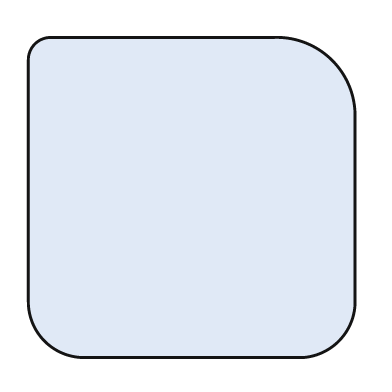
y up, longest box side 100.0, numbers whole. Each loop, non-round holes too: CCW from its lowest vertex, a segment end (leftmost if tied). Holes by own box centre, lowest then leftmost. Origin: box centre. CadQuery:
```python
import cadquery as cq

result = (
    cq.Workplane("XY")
    .moveTo(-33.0, -49.0)
    .lineTo(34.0, -49.0)
    .threePointArc((45.0, -44.0), (50.0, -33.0))
    .lineTo(50.0, 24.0)
    .threePointArc((43.0, 42.0), (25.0, 49.0))
    .lineTo(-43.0, 49.0)
    .threePointArc((-48.0, 47.0), (-50.0, 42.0))
    .lineTo(-50.0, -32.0)
    .threePointArc((-45.0, -44.0), (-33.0, -49.0))
    .close()
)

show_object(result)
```